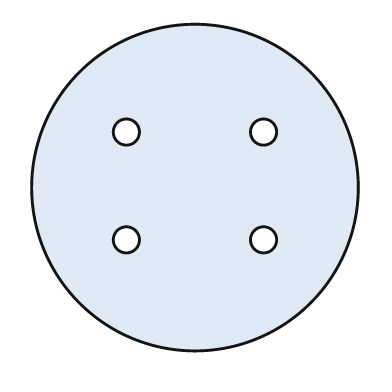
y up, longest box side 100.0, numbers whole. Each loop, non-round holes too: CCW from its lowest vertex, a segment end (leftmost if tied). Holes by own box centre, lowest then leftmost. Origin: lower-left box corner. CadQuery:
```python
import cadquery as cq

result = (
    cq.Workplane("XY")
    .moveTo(50.0, 50.0)
    .circle(50.0)
    .moveTo(29.0, 34.0)
    .circle(4.0)
    .moveTo(71.0, 34.0)
    .circle(4.0)
    .moveTo(29.0, 67.0)
    .circle(4.0)
    .moveTo(71.0, 67.0)
    .circle(4.0)
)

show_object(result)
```